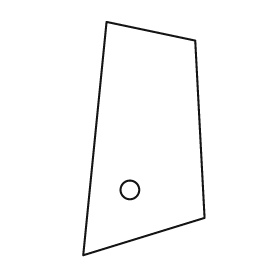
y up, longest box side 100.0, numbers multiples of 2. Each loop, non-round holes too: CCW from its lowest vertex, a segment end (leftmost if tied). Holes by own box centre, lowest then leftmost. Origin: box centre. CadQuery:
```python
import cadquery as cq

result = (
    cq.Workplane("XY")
    .moveTo(-26.0, -50.0)
    .lineTo(26.0, -34.0)
    .lineTo(22.0, 42.0)
    .lineTo(-16.0, 50.0)
    .close()
    .moveTo(-6.0, -22.0)
    .circle(4.0)
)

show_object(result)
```